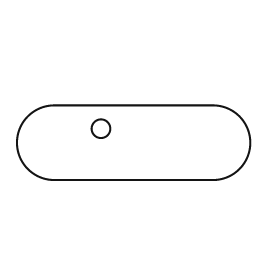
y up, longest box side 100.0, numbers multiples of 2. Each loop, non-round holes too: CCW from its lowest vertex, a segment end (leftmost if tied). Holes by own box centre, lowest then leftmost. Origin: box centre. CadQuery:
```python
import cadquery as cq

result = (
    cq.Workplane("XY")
    .moveTo(-34.0, -16.0)
    .lineTo(34.0, -16.0)
    .threePointArc((50.0, 0.0), (34.0, 16.0))
    .lineTo(-34.0, 16.0)
    .threePointArc((-50.0, 0.0), (-34.0, -16.0))
    .close()
    .moveTo(-14.0, 6.0)
    .circle(4.0)
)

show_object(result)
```